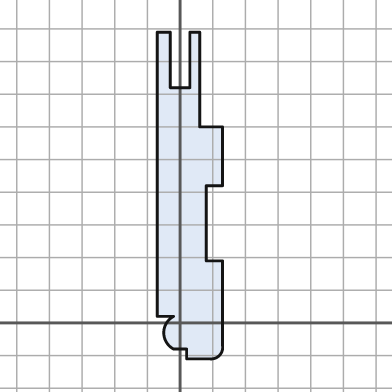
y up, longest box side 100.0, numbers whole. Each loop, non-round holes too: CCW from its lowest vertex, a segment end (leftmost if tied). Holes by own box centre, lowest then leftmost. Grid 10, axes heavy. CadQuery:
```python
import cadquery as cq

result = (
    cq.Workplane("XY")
    .moveTo(2.0, -11.0)
    .lineTo(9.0, -11.0)
    .threePointArc((12.0, -10.0), (13.0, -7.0))
    .lineTo(13.0, 19.0)
    .lineTo(8.0, 19.0)
    .lineTo(8.0, 42.0)
    .lineTo(13.0, 42.0)
    .lineTo(13.0, 60.0)
    .lineTo(6.0, 60.0)
    .lineTo(6.0, 89.0)
    .lineTo(3.0, 89.0)
    .lineTo(3.0, 72.0)
    .lineTo(-3.0, 72.0)
    .lineTo(-3.0, 89.0)
    .lineTo(-7.0, 89.0)
    .lineTo(-7.0, 2.0)
    .lineTo(-2.0, 2.0)
    .threePointArc((-5.0, -3.0), (-2.0, -8.0))
    .lineTo(2.0, -8.0)
    .close()
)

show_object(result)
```